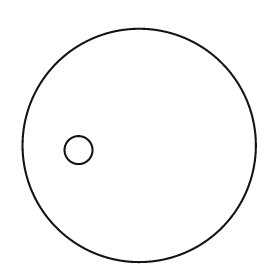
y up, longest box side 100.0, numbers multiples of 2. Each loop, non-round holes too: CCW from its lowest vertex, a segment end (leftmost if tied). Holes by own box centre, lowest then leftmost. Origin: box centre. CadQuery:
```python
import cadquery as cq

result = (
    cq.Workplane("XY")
    .moveTo(0.0, 0.0)
    .circle(50.0)
    .moveTo(-26.0, -2.0)
    .circle(6.0)
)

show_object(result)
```